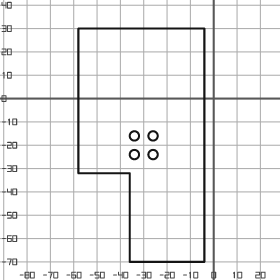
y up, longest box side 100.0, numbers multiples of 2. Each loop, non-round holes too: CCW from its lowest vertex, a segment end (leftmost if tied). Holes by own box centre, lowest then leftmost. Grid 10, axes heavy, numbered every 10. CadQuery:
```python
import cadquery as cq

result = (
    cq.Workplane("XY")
    .moveTo(-36.0, -70.0)
    .lineTo(-4.0, -70.0)
    .lineTo(-4.0, 30.0)
    .lineTo(-58.0, 30.0)
    .lineTo(-58.0, -32.0)
    .lineTo(-36.0, -32.0)
    .close()
    .moveTo(-34.0, -24.0)
    .circle(2.0)
    .moveTo(-26.0, -24.0)
    .circle(2.0)
    .moveTo(-34.0, -16.0)
    .circle(2.0)
    .moveTo(-26.0, -16.0)
    .circle(2.0)
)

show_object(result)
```